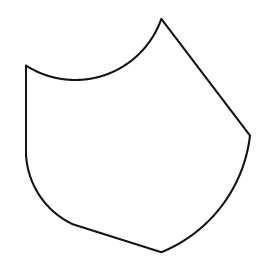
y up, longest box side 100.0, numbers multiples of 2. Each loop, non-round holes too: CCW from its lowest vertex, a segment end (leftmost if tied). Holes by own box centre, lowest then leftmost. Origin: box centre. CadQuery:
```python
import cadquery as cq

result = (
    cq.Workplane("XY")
    .moveTo(10.0, -50.0)
    .threePointArc((36.0, -30.0), (48.0, 0.0))
    .lineTo(10.0, 50.0)
    .threePointArc((-14.0, 26.0), (-48.0, 30.0))
    .lineTo(-48.0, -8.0)
    .threePointArc((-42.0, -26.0), (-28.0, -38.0))
    .close()
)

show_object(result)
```